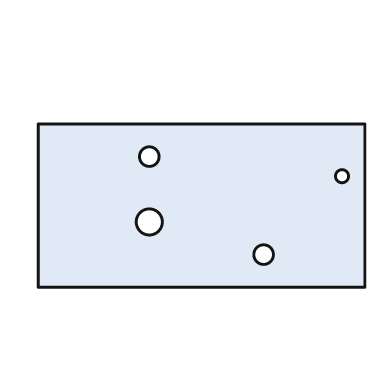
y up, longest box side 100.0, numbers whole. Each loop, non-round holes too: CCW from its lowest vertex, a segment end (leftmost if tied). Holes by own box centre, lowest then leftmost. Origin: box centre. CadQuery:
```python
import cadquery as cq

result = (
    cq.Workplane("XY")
    .moveTo(-50.0, -25.0)
    .lineTo(50.0, -25.0)
    .lineTo(50.0, 25.0)
    .lineTo(-50.0, 25.0)
    .close()
    .moveTo(19.0, -15.0)
    .circle(3.0)
    .moveTo(-16.0, -5.0)
    .circle(4.0)
    .moveTo(43.0, 9.0)
    .circle(2.0)
    .moveTo(-16.0, 15.0)
    .circle(3.0)
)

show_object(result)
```